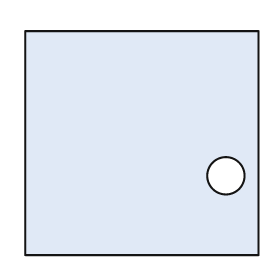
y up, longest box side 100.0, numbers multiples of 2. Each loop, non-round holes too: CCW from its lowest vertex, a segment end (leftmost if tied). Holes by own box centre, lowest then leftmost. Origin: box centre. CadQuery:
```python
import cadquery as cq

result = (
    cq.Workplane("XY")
    .moveTo(-50.0, -48.0)
    .lineTo(50.0, -48.0)
    .lineTo(50.0, 48.0)
    .lineTo(-50.0, 48.0)
    .close()
    .moveTo(36.0, -14.0)
    .circle(8.0)
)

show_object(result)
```